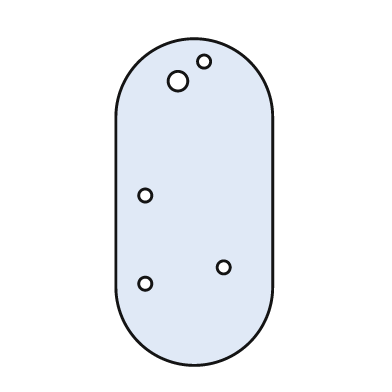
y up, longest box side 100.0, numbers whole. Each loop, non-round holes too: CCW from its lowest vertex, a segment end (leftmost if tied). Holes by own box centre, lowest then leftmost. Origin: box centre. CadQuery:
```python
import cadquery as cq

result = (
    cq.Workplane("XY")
    .moveTo(-24.0, -26.0)
    .threePointArc((0.0, -50.0), (24.0, -26.0))
    .lineTo(24.0, 26.0)
    .threePointArc((0.0, 50.0), (-24.0, 26.0))
    .close()
    .moveTo(-15.0, -25.0)
    .circle(2.0)
    .moveTo(9.0, -20.0)
    .circle(2.0)
    .moveTo(-15.0, 2.0)
    .circle(2.0)
    .moveTo(-5.0, 37.0)
    .circle(3.0)
    .moveTo(3.0, 43.0)
    .circle(2.0)
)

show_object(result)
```